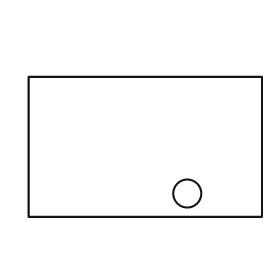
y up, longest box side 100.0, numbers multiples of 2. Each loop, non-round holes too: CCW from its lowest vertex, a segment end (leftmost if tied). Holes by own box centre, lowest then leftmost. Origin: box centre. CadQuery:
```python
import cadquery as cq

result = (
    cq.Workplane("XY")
    .moveTo(-50.0, -30.0)
    .lineTo(50.0, -30.0)
    .lineTo(50.0, 30.0)
    .lineTo(-50.0, 30.0)
    .close()
    .moveTo(18.0, -20.0)
    .circle(6.0)
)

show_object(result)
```